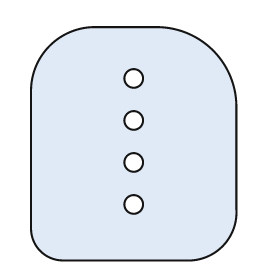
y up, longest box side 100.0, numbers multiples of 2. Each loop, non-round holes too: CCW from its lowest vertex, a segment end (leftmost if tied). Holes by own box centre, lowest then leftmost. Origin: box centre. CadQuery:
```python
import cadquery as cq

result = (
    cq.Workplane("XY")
    .moveTo(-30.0, -50.0)
    .lineTo(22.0, -50.0)
    .threePointArc((38.0, -44.0), (44.0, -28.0))
    .lineTo(44.0, 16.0)
    .threePointArc((34.0, 40.0), (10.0, 50.0))
    .lineTo(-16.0, 50.0)
    .threePointArc((-36.0, 42.0), (-44.0, 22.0))
    .lineTo(-44.0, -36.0)
    .threePointArc((-40.0, -46.0), (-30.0, -50.0))
    .close()
    .moveTo(0.0, -26.0)
    .circle(4.0)
    .moveTo(0.0, -8.0)
    .circle(4.0)
    .moveTo(0.0, 10.0)
    .circle(4.0)
    .moveTo(0.0, 28.0)
    .circle(4.0)
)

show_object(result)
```